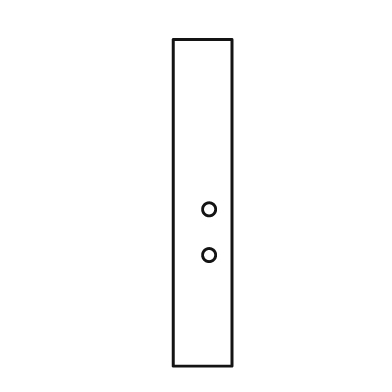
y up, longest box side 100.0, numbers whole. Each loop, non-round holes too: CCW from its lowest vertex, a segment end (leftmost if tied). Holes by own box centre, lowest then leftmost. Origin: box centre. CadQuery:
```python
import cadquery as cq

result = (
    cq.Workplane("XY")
    .moveTo(-9.0, -50.0)
    .lineTo(9.0, -50.0)
    .lineTo(9.0, 50.0)
    .lineTo(-9.0, 50.0)
    .close()
    .moveTo(2.0, -16.0)
    .circle(2.0)
    .moveTo(2.0, -2.0)
    .circle(2.0)
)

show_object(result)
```